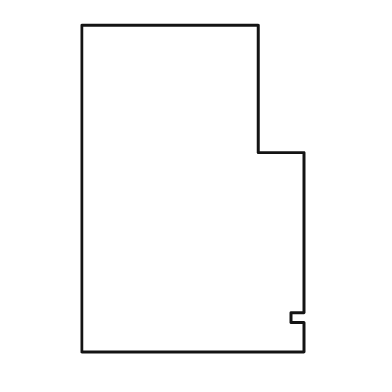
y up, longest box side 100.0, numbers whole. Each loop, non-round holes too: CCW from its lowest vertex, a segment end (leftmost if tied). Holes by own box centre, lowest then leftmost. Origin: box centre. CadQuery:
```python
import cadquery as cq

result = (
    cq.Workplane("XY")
    .moveTo(-34.0, -50.0)
    .lineTo(34.0, -50.0)
    .lineTo(34.0, -41.0)
    .lineTo(30.0, -41.0)
    .lineTo(30.0, -38.0)
    .lineTo(34.0, -38.0)
    .lineTo(34.0, 11.0)
    .lineTo(20.0, 11.0)
    .lineTo(20.0, 50.0)
    .lineTo(-34.0, 50.0)
    .close()
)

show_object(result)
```